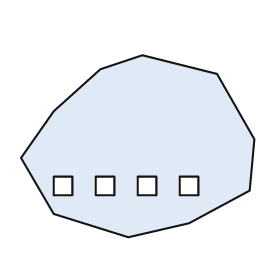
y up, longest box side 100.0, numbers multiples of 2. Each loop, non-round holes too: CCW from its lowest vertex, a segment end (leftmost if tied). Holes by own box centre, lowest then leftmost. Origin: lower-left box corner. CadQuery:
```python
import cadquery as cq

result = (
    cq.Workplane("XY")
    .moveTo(46.0, 0.0)
    .lineTo(72.0, 6.0)
    .lineTo(98.0, 20.0)
    .lineTo(100.0, 42.0)
    .lineTo(84.0, 70.0)
    .lineTo(52.0, 78.0)
    .lineTo(34.0, 72.0)
    .lineTo(14.0, 54.0)
    .lineTo(0.0, 34.0)
    .lineTo(14.0, 10.0)
    .close()
    .moveTo(14.0, 18.0)
    .lineTo(22.0, 18.0)
    .lineTo(22.0, 26.0)
    .lineTo(14.0, 26.0)
    .close()
    .moveTo(32.0, 18.0)
    .lineTo(40.0, 18.0)
    .lineTo(40.0, 26.0)
    .lineTo(32.0, 26.0)
    .close()
    .moveTo(50.0, 18.0)
    .lineTo(58.0, 18.0)
    .lineTo(58.0, 26.0)
    .lineTo(50.0, 26.0)
    .close()
    .moveTo(68.0, 18.0)
    .lineTo(76.0, 18.0)
    .lineTo(76.0, 26.0)
    .lineTo(68.0, 26.0)
    .close()
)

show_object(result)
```